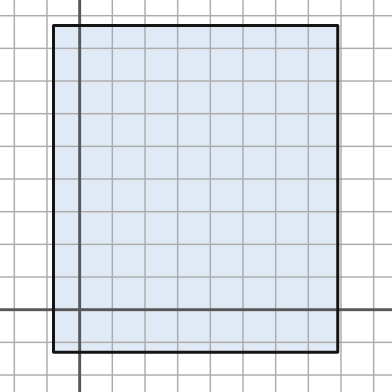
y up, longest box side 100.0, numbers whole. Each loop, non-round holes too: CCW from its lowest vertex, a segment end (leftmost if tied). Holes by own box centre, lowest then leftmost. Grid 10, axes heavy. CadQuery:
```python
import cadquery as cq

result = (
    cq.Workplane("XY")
    .moveTo(-8.0, -13.0)
    .lineTo(79.0, -13.0)
    .lineTo(79.0, 87.0)
    .lineTo(-8.0, 87.0)
    .close()
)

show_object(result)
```